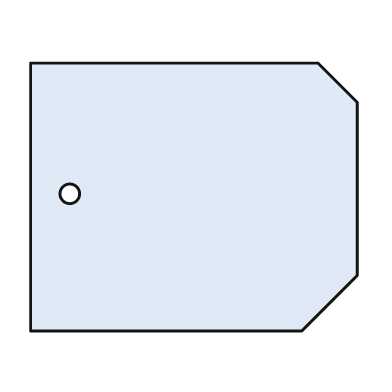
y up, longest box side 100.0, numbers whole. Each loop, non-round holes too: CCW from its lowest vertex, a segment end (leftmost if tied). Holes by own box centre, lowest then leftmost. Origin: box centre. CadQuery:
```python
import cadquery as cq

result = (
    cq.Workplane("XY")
    .moveTo(-50.0, -41.0)
    .lineTo(33.0, -41.0)
    .lineTo(50.0, -24.0)
    .lineTo(50.0, 29.0)
    .lineTo(38.0, 41.0)
    .lineTo(-50.0, 41.0)
    .close()
    .moveTo(-38.0, 1.0)
    .circle(3.0)
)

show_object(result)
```